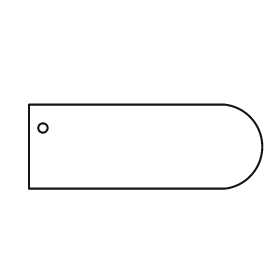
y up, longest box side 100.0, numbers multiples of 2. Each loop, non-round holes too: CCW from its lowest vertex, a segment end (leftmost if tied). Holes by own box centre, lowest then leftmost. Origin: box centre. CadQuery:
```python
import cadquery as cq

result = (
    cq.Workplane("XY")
    .moveTo(-50.0, -18.0)
    .lineTo(34.0, -18.0)
    .threePointArc((50.0, 0.0), (34.0, 18.0))
    .lineTo(-50.0, 18.0)
    .close()
    .moveTo(-44.0, 8.0)
    .circle(2.0)
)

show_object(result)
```